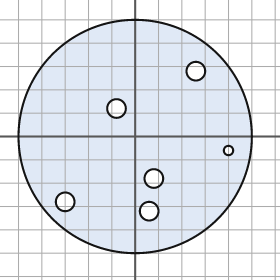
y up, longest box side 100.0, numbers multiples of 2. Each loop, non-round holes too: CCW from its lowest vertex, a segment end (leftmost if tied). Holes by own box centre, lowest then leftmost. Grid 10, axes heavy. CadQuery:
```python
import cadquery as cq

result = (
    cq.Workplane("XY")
    .moveTo(0.0, 0.0)
    .circle(50.0)
    .moveTo(6.0, -32.0)
    .circle(4.0)
    .moveTo(-30.0, -28.0)
    .circle(4.0)
    .moveTo(8.0, -18.0)
    .circle(4.0)
    .moveTo(40.0, -6.0)
    .circle(2.0)
    .moveTo(-8.0, 12.0)
    .circle(4.0)
    .moveTo(26.0, 28.0)
    .circle(4.0)
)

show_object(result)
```